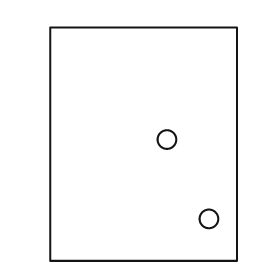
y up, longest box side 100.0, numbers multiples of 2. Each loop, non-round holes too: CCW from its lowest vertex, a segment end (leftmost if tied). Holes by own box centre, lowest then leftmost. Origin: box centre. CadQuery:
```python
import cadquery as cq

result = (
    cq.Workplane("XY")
    .moveTo(-40.0, -50.0)
    .lineTo(40.0, -50.0)
    .lineTo(40.0, 50.0)
    .lineTo(-40.0, 50.0)
    .close()
    .moveTo(28.0, -32.0)
    .circle(4.0)
    .moveTo(10.0, 2.0)
    .circle(4.0)
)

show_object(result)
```